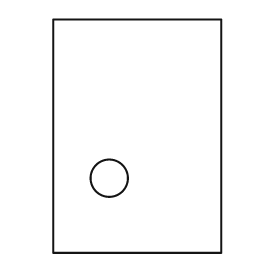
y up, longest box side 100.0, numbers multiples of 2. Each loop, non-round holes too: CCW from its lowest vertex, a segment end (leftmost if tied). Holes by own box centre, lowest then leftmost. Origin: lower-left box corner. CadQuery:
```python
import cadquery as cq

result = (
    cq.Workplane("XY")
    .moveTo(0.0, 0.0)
    .lineTo(72.0, 0.0)
    .lineTo(72.0, 100.0)
    .lineTo(0.0, 100.0)
    .close()
    .moveTo(24.0, 32.0)
    .circle(8.0)
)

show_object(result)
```